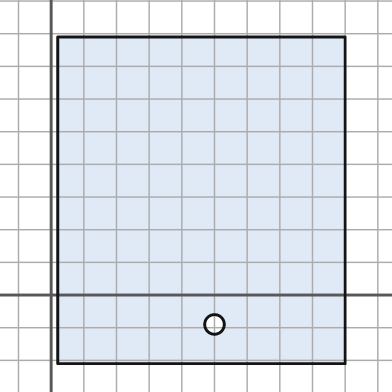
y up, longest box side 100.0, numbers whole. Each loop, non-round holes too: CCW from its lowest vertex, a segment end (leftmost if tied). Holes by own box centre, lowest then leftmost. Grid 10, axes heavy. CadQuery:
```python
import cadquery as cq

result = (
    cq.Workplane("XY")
    .moveTo(2.0, -21.0)
    .lineTo(90.0, -21.0)
    .lineTo(90.0, 79.0)
    .lineTo(2.0, 79.0)
    .close()
    .moveTo(50.0, -9.0)
    .circle(3.0)
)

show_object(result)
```